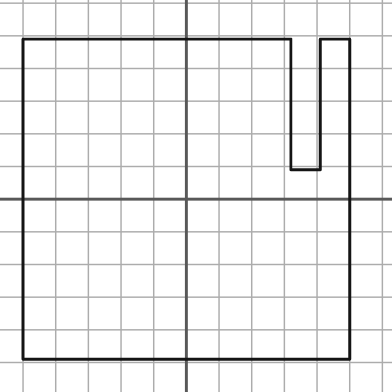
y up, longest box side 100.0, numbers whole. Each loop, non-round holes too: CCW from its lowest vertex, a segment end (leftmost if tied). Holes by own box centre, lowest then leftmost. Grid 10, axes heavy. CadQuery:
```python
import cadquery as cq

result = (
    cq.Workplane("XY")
    .moveTo(-50.0, -49.0)
    .lineTo(50.0, -49.0)
    .lineTo(50.0, 49.0)
    .lineTo(41.0, 49.0)
    .lineTo(41.0, 9.0)
    .lineTo(32.0, 9.0)
    .lineTo(32.0, 49.0)
    .lineTo(-50.0, 49.0)
    .close()
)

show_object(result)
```